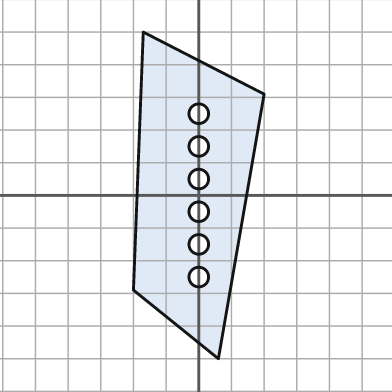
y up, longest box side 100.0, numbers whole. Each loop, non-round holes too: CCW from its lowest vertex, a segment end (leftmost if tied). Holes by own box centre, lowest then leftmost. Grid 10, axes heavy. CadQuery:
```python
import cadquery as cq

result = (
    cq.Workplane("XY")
    .moveTo(6.0, -50.0)
    .lineTo(20.0, 31.0)
    .lineTo(-17.0, 50.0)
    .lineTo(-20.0, -29.0)
    .close()
    .moveTo(0.0, -25.0)
    .circle(3.0)
    .moveTo(0.0, -15.0)
    .circle(3.0)
    .moveTo(0.0, -5.0)
    .circle(3.0)
    .moveTo(0.0, 5.0)
    .circle(3.0)
    .moveTo(0.0, 15.0)
    .circle(3.0)
    .moveTo(0.0, 25.0)
    .circle(3.0)
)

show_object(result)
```